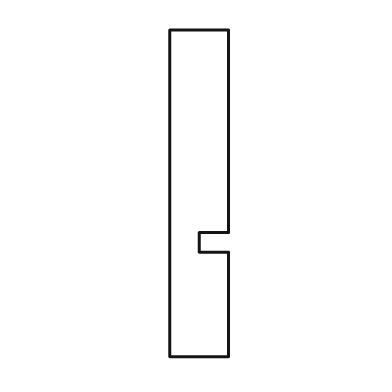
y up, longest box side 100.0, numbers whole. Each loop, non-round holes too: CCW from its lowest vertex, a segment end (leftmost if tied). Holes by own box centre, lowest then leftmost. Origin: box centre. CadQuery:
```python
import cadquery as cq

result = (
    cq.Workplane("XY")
    .moveTo(-9.0, -50.0)
    .lineTo(9.0, -50.0)
    .lineTo(9.0, -18.0)
    .lineTo(0.0, -18.0)
    .lineTo(0.0, -12.0)
    .lineTo(9.0, -12.0)
    .lineTo(9.0, 50.0)
    .lineTo(-9.0, 50.0)
    .close()
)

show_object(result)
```